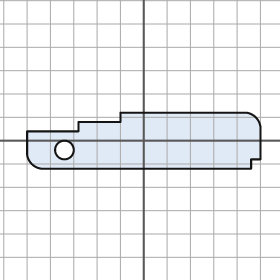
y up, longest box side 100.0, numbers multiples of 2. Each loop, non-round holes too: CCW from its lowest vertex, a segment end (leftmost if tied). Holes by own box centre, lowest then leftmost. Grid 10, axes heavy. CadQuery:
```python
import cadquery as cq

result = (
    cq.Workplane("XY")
    .moveTo(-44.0, -12.0)
    .lineTo(46.0, -12.0)
    .lineTo(46.0, -8.0)
    .lineTo(50.0, -8.0)
    .lineTo(50.0, 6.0)
    .threePointArc((48.0, 10.0), (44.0, 12.0))
    .lineTo(-10.0, 12.0)
    .lineTo(-10.0, 8.0)
    .lineTo(-28.0, 8.0)
    .lineTo(-28.0, 4.0)
    .lineTo(-50.0, 4.0)
    .lineTo(-50.0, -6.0)
    .threePointArc((-48.0, -10.0), (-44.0, -12.0))
    .close()
    .moveTo(-34.0, -4.0)
    .circle(4.0)
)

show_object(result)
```